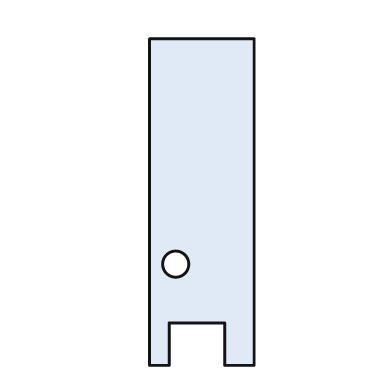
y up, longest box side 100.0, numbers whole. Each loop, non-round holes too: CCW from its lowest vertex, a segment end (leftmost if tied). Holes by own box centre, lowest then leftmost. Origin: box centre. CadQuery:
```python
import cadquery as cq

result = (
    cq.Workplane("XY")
    .moveTo(-16.0, -50.0)
    .lineTo(-10.0, -50.0)
    .lineTo(-10.0, -37.0)
    .lineTo(7.0, -37.0)
    .lineTo(7.0, -50.0)
    .lineTo(16.0, -50.0)
    .lineTo(16.0, 50.0)
    .lineTo(-16.0, 50.0)
    .close()
    .moveTo(-8.0, -19.0)
    .circle(4.0)
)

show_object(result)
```